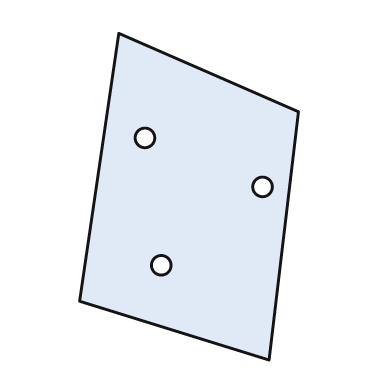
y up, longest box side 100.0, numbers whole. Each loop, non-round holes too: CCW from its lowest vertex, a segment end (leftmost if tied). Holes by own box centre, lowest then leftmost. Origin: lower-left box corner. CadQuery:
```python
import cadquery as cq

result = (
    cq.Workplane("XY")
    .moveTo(58.0, 0.0)
    .lineTo(67.0, 76.0)
    .lineTo(12.0, 100.0)
    .lineTo(0.0, 18.0)
    .close()
    .moveTo(25.0, 29.0)
    .circle(3.0)
    .moveTo(56.0, 53.0)
    .circle(3.0)
    .moveTo(20.0, 68.0)
    .circle(3.0)
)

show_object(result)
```